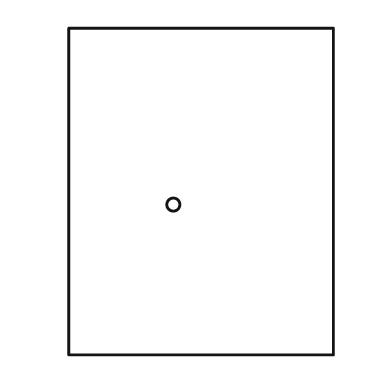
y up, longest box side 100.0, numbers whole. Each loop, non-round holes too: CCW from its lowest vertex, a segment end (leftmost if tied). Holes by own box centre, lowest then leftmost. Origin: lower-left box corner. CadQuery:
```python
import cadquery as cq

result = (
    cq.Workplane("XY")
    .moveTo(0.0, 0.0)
    .lineTo(81.0, 0.0)
    .lineTo(81.0, 100.0)
    .lineTo(0.0, 100.0)
    .close()
    .moveTo(32.0, 46.0)
    .circle(2.0)
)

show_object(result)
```